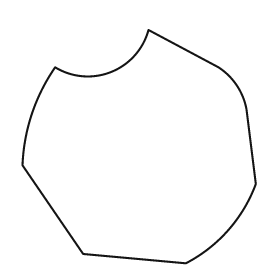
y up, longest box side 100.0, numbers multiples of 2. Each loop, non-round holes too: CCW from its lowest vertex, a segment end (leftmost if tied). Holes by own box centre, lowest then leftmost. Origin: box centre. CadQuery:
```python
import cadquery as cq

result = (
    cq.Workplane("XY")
    .moveTo(20.0, -50.0)
    .threePointArc((38.0, -36.0), (50.0, -16.0))
    .lineTo(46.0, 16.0)
    .threePointArc((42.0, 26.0), (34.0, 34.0))
    .lineTo(4.0, 50.0)
    .threePointArc((-12.0, 32.0), (-36.0, 34.0))
    .threePointArc((-46.0, 14.0), (-50.0, -8.0))
    .lineTo(-24.0, -46.0)
    .close()
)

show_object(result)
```